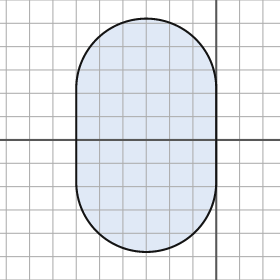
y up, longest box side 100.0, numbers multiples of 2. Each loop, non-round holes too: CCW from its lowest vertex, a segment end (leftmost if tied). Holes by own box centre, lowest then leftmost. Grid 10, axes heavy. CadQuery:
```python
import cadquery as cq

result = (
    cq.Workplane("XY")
    .moveTo(-60.0, -18.0)
    .threePointArc((-30.0, -48.0), (0.0, -18.0))
    .lineTo(0.0, 22.0)
    .threePointArc((-30.0, 52.0), (-60.0, 22.0))
    .close()
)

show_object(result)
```